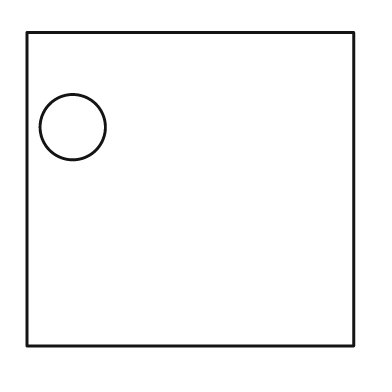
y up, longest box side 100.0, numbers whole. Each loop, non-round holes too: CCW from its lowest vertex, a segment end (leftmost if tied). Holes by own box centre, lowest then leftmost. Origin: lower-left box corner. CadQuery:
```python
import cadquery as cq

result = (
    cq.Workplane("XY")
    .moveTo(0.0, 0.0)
    .lineTo(100.0, 0.0)
    .lineTo(100.0, 96.0)
    .lineTo(0.0, 96.0)
    .close()
    .moveTo(14.0, 67.0)
    .circle(10.0)
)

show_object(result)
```